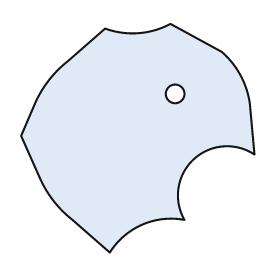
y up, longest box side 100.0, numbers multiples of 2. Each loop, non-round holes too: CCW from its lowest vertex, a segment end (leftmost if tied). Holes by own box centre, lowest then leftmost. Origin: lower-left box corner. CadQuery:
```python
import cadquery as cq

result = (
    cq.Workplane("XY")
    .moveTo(38.0, 0.0)
    .threePointArc((52.0, 12.0), (70.0, 14.0))
    .threePointArc((74.0, 40.0), (100.0, 42.0))
    .lineTo(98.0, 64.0)
    .threePointArc((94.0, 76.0), (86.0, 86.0))
    .lineTo(64.0, 98.0)
    .threePointArc((50.0, 94.0), (36.0, 96.0))
    .lineTo(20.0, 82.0)
    .threePointArc((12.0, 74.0), (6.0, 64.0))
    .lineTo(0.0, 50.0)
    .lineTo(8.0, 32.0)
    .threePointArc((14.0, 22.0), (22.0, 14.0))
    .close()
    .moveTo(66.0, 68.0)
    .circle(4.0)
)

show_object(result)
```